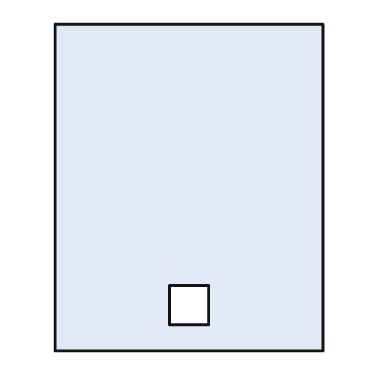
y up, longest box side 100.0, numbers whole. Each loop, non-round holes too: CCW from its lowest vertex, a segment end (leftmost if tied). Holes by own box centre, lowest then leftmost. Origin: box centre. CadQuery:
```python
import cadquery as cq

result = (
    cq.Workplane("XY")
    .moveTo(-41.0, -50.0)
    .lineTo(41.0, -50.0)
    .lineTo(41.0, 50.0)
    .lineTo(-41.0, 50.0)
    .close()
    .moveTo(-6.0, -42.0)
    .lineTo(6.0, -42.0)
    .lineTo(6.0, -30.0)
    .lineTo(-6.0, -30.0)
    .close()
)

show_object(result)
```